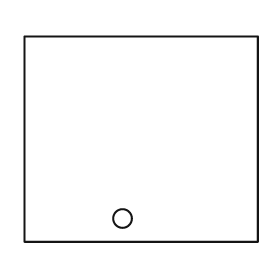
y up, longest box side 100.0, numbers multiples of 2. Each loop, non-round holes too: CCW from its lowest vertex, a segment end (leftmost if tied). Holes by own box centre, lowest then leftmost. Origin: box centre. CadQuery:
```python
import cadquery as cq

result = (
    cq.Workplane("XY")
    .moveTo(-50.0, -44.0)
    .lineTo(50.0, -44.0)
    .lineTo(50.0, 44.0)
    .lineTo(-50.0, 44.0)
    .close()
    .moveTo(-8.0, -34.0)
    .circle(4.0)
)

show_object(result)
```